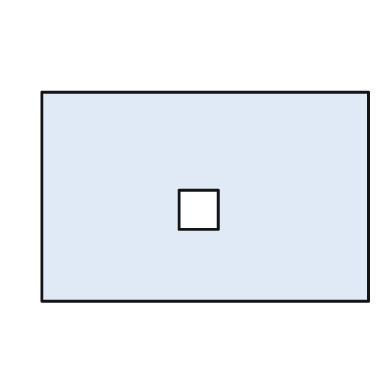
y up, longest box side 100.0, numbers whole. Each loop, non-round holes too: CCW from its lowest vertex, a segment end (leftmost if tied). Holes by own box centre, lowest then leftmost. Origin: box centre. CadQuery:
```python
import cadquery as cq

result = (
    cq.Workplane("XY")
    .moveTo(-50.0, -32.0)
    .lineTo(50.0, -32.0)
    .lineTo(50.0, 32.0)
    .lineTo(-50.0, 32.0)
    .close()
    .moveTo(-8.0, -10.0)
    .lineTo(4.0, -10.0)
    .lineTo(4.0, 2.0)
    .lineTo(-8.0, 2.0)
    .close()
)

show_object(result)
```